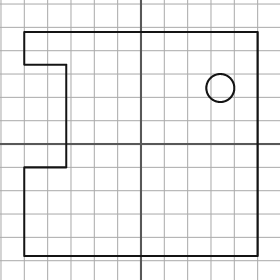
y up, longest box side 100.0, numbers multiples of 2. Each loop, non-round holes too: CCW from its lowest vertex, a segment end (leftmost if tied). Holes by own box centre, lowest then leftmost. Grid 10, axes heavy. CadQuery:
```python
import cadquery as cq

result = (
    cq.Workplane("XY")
    .moveTo(-50.0, -48.0)
    .lineTo(50.0, -48.0)
    .lineTo(50.0, 48.0)
    .lineTo(-50.0, 48.0)
    .lineTo(-50.0, 34.0)
    .lineTo(-32.0, 34.0)
    .lineTo(-32.0, -10.0)
    .lineTo(-50.0, -10.0)
    .close()
    .moveTo(34.0, 24.0)
    .circle(6.0)
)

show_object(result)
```